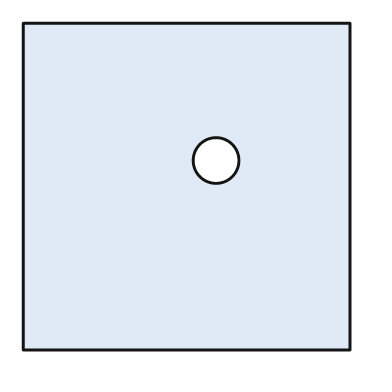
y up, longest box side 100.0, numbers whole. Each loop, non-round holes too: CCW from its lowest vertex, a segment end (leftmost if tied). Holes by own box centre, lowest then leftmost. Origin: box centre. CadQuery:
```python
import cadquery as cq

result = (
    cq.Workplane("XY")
    .moveTo(-50.0, -50.0)
    .lineTo(50.0, -50.0)
    .lineTo(50.0, 50.0)
    .lineTo(-50.0, 50.0)
    .close()
    .moveTo(9.0, 8.0)
    .circle(7.0)
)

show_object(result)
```